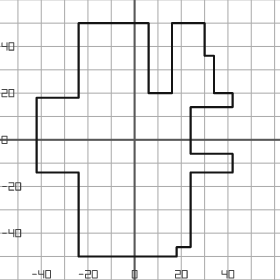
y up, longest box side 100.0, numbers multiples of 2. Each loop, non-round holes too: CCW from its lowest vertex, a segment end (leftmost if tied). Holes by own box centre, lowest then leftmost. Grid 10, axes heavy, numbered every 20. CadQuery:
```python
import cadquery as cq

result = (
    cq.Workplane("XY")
    .moveTo(-24.0, -50.0)
    .lineTo(18.0, -50.0)
    .lineTo(18.0, -46.0)
    .lineTo(24.0, -46.0)
    .lineTo(24.0, -14.0)
    .lineTo(42.0, -14.0)
    .lineTo(42.0, -6.0)
    .lineTo(24.0, -6.0)
    .lineTo(24.0, 14.0)
    .lineTo(42.0, 14.0)
    .lineTo(42.0, 20.0)
    .lineTo(34.0, 20.0)
    .lineTo(34.0, 36.0)
    .lineTo(30.0, 36.0)
    .lineTo(30.0, 50.0)
    .lineTo(16.0, 50.0)
    .lineTo(16.0, 20.0)
    .lineTo(6.0, 20.0)
    .lineTo(6.0, 50.0)
    .lineTo(-24.0, 50.0)
    .lineTo(-24.0, 18.0)
    .lineTo(-42.0, 18.0)
    .lineTo(-42.0, -14.0)
    .lineTo(-24.0, -14.0)
    .close()
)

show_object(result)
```